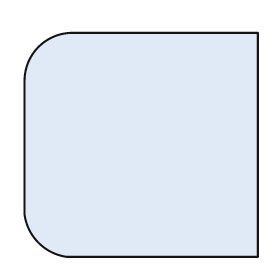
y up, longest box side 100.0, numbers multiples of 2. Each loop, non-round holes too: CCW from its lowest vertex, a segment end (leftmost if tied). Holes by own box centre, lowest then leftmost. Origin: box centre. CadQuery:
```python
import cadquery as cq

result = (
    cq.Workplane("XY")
    .moveTo(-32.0, -48.0)
    .lineTo(50.0, -48.0)
    .lineTo(50.0, 48.0)
    .lineTo(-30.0, 48.0)
    .threePointArc((-44.0, 42.0), (-50.0, 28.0))
    .lineTo(-50.0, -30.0)
    .threePointArc((-44.0, -42.0), (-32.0, -48.0))
    .close()
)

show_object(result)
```